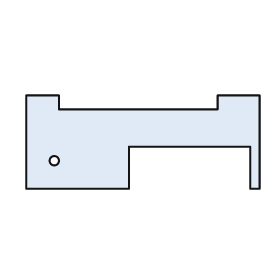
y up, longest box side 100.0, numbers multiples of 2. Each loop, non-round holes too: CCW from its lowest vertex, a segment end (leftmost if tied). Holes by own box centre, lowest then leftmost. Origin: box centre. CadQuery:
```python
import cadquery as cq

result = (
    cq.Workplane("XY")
    .moveTo(-50.0, -20.0)
    .lineTo(-6.0, -20.0)
    .lineTo(-6.0, -2.0)
    .lineTo(46.0, -2.0)
    .lineTo(46.0, -20.0)
    .lineTo(50.0, -20.0)
    .lineTo(50.0, 20.0)
    .lineTo(32.0, 20.0)
    .lineTo(32.0, 14.0)
    .lineTo(-36.0, 14.0)
    .lineTo(-36.0, 20.0)
    .lineTo(-50.0, 20.0)
    .close()
    .moveTo(-38.0, -8.0)
    .circle(2.0)
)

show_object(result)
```